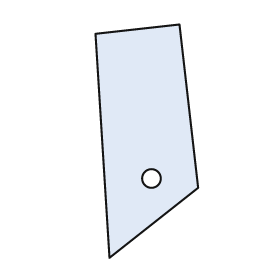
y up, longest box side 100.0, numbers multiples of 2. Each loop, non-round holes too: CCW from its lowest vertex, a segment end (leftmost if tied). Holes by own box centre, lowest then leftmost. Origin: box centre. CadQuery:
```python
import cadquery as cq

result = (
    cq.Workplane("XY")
    .moveTo(-16.0, -50.0)
    .lineTo(22.0, -20.0)
    .lineTo(14.0, 50.0)
    .lineTo(-22.0, 46.0)
    .close()
    .moveTo(2.0, -16.0)
    .circle(4.0)
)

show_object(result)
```